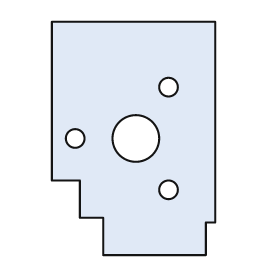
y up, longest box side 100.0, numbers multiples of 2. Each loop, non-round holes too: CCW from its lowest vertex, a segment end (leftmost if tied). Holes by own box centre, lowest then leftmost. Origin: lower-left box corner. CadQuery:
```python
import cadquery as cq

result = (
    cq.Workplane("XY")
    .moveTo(22.0, 0.0)
    .lineTo(66.0, 0.0)
    .lineTo(66.0, 14.0)
    .lineTo(70.0, 14.0)
    .lineTo(70.0, 100.0)
    .lineTo(0.0, 100.0)
    .lineTo(0.0, 32.0)
    .lineTo(12.0, 32.0)
    .lineTo(12.0, 16.0)
    .lineTo(22.0, 16.0)
    .close()
    .moveTo(50.0, 28.0)
    .circle(4.0)
    .moveTo(10.0, 50.0)
    .circle(4.0)
    .moveTo(36.0, 50.0)
    .circle(10.0)
    .moveTo(50.0, 72.0)
    .circle(4.0)
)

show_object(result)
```